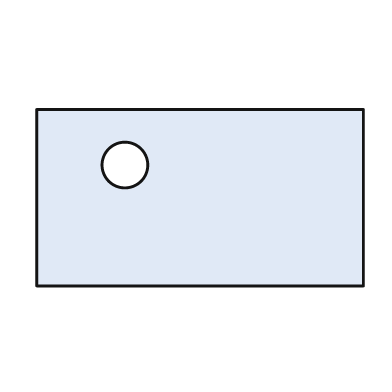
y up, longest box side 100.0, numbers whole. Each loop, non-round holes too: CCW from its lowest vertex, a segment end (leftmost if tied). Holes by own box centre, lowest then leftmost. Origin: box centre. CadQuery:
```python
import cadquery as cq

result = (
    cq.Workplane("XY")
    .moveTo(-50.0, -27.0)
    .lineTo(50.0, -27.0)
    .lineTo(50.0, 27.0)
    .lineTo(-50.0, 27.0)
    .close()
    .moveTo(-23.0, 10.0)
    .circle(7.0)
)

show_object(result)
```